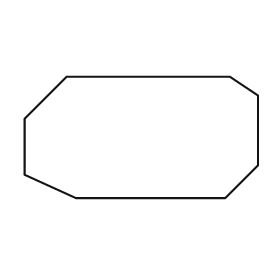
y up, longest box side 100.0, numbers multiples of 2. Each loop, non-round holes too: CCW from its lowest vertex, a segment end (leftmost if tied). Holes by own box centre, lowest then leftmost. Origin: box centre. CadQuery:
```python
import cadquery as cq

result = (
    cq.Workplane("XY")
    .moveTo(-28.0, -26.0)
    .lineTo(36.0, -26.0)
    .lineTo(50.0, -12.0)
    .lineTo(50.0, 18.0)
    .lineTo(38.0, 26.0)
    .lineTo(-32.0, 26.0)
    .lineTo(-50.0, 8.0)
    .lineTo(-50.0, -16.0)
    .close()
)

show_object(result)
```